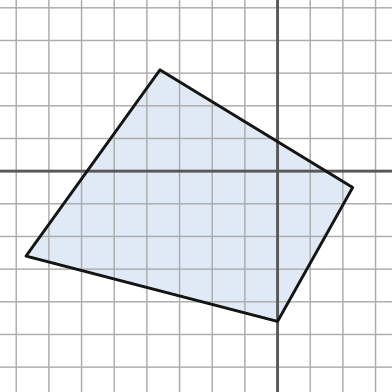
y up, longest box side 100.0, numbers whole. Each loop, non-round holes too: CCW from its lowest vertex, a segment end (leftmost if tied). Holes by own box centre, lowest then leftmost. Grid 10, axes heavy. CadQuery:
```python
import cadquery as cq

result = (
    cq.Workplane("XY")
    .moveTo(0.0, -46.0)
    .lineTo(23.0, -5.0)
    .lineTo(-36.0, 31.0)
    .lineTo(-77.0, -26.0)
    .close()
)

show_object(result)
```